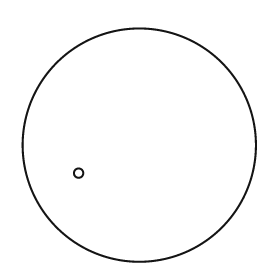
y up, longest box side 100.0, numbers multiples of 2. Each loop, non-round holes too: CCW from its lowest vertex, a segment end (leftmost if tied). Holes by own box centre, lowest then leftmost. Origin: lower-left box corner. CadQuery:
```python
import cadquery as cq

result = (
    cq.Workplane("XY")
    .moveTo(50.0, 50.0)
    .circle(50.0)
    .moveTo(24.0, 38.0)
    .circle(2.0)
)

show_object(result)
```